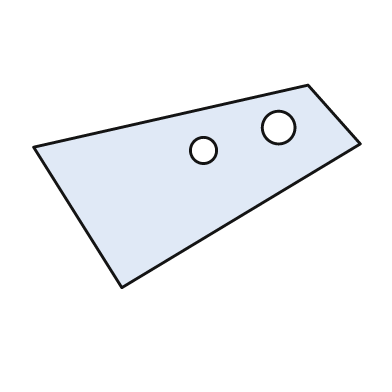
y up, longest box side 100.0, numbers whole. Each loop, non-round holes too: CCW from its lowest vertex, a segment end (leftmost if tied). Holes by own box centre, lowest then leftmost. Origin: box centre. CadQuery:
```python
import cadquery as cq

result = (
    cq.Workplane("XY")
    .moveTo(-23.0, -31.0)
    .lineTo(50.0, 13.0)
    .lineTo(34.0, 31.0)
    .lineTo(-50.0, 12.0)
    .close()
    .moveTo(2.0, 11.0)
    .circle(4.0)
    .moveTo(25.0, 18.0)
    .circle(5.0)
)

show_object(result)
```